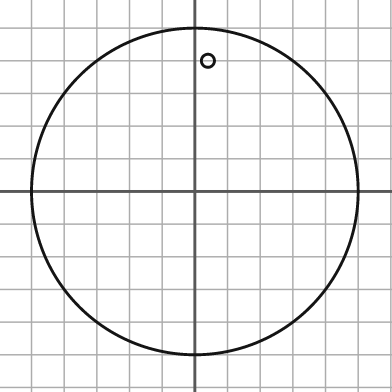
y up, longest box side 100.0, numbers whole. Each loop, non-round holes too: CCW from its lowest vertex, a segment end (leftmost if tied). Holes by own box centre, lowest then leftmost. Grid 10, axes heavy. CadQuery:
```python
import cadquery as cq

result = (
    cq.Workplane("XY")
    .moveTo(0.0, 0.0)
    .circle(50.0)
    .moveTo(4.0, 40.0)
    .circle(2.0)
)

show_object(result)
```